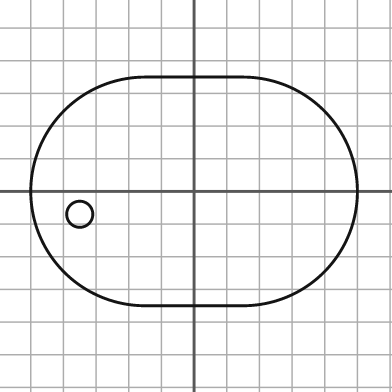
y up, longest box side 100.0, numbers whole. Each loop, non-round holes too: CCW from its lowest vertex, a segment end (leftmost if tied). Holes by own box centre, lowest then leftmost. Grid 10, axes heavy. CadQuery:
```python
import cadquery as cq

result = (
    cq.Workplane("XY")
    .moveTo(-15.0, -35.0)
    .lineTo(15.0, -35.0)
    .threePointArc((50.0, 0.0), (15.0, 35.0))
    .lineTo(-15.0, 35.0)
    .threePointArc((-50.0, 0.0), (-15.0, -35.0))
    .close()
    .moveTo(-35.0, -7.0)
    .circle(4.0)
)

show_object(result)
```